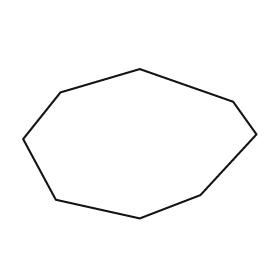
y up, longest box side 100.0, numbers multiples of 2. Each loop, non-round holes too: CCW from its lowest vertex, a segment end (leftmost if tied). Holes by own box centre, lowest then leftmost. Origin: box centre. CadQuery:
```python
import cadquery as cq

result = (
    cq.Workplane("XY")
    .moveTo(0.0, -32.0)
    .lineTo(26.0, -22.0)
    .lineTo(50.0, 4.0)
    .lineTo(40.0, 18.0)
    .lineTo(0.0, 32.0)
    .lineTo(-34.0, 22.0)
    .lineTo(-50.0, 2.0)
    .lineTo(-36.0, -24.0)
    .close()
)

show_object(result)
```